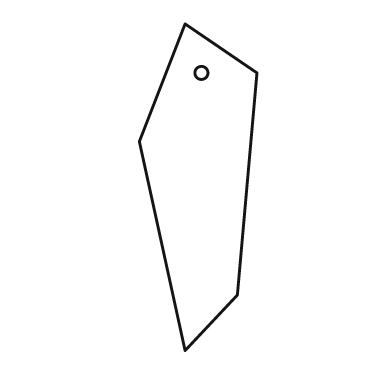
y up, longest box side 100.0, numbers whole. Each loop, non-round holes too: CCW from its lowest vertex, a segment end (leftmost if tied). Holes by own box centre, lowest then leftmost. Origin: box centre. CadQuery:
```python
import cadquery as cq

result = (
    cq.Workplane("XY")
    .moveTo(-4.0, -50.0)
    .lineTo(12.0, -33.0)
    .lineTo(18.0, 35.0)
    .lineTo(-4.0, 50.0)
    .lineTo(-18.0, 14.0)
    .close()
    .moveTo(1.0, 35.0)
    .circle(2.0)
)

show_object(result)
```